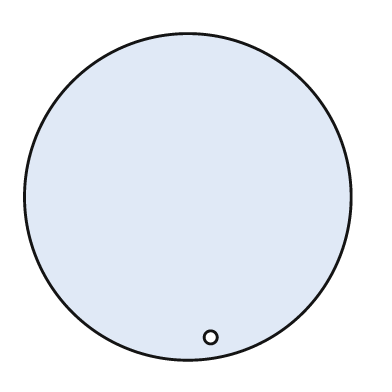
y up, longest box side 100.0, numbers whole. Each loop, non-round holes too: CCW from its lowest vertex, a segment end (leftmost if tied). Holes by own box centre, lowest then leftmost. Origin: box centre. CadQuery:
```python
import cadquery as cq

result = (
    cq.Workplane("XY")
    .moveTo(0.0, 0.0)
    .circle(50.0)
    .moveTo(7.0, -43.0)
    .circle(2.0)
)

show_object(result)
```